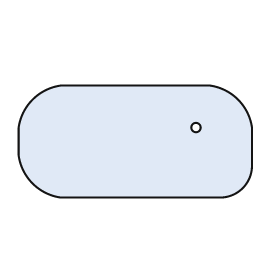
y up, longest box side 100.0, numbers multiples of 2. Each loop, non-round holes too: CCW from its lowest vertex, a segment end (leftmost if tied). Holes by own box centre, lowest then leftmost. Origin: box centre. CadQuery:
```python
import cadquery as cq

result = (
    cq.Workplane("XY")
    .moveTo(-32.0, -24.0)
    .lineTo(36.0, -24.0)
    .threePointArc((46.0, -20.0), (50.0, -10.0))
    .lineTo(50.0, 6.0)
    .threePointArc((44.0, 18.0), (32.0, 24.0))
    .lineTo(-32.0, 24.0)
    .threePointArc((-44.0, 18.0), (-50.0, 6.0))
    .lineTo(-50.0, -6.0)
    .threePointArc((-44.0, -18.0), (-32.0, -24.0))
    .close()
    .moveTo(26.0, 6.0)
    .circle(2.0)
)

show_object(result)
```